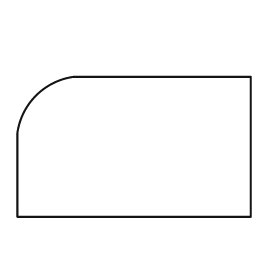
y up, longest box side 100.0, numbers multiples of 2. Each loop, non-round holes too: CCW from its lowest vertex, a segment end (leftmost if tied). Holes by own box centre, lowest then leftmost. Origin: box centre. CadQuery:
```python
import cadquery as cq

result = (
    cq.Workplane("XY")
    .moveTo(-50.0, -30.0)
    .lineTo(50.0, -30.0)
    .lineTo(50.0, 30.0)
    .lineTo(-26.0, 30.0)
    .threePointArc((-42.0, 22.0), (-50.0, 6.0))
    .close()
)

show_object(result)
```